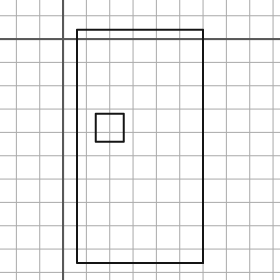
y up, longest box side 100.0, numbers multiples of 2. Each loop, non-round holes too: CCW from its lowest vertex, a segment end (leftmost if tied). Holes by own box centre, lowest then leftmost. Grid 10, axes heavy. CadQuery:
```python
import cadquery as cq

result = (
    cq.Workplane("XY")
    .moveTo(6.0, -96.0)
    .lineTo(60.0, -96.0)
    .lineTo(60.0, 4.0)
    .lineTo(6.0, 4.0)
    .close()
    .moveTo(14.0, -44.0)
    .lineTo(26.0, -44.0)
    .lineTo(26.0, -32.0)
    .lineTo(14.0, -32.0)
    .close()
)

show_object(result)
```